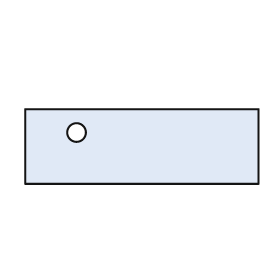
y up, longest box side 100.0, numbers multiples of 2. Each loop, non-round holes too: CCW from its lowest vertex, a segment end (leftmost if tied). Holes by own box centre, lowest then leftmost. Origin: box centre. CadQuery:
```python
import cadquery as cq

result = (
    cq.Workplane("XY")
    .moveTo(-50.0, -16.0)
    .lineTo(50.0, -16.0)
    .lineTo(50.0, 16.0)
    .lineTo(-50.0, 16.0)
    .close()
    .moveTo(-28.0, 6.0)
    .circle(4.0)
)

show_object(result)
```